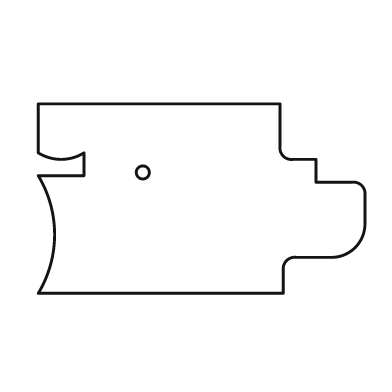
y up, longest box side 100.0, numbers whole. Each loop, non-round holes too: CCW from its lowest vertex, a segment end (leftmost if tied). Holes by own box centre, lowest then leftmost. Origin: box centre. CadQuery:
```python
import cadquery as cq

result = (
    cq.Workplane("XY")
    .moveTo(-50.0, -29.0)
    .lineTo(25.0, -29.0)
    .lineTo(25.0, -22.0)
    .threePointArc((26.0, -19.0), (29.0, -18.0))
    .lineTo(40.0, -18.0)
    .threePointArc((47.0, -15.0), (50.0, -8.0))
    .lineTo(50.0, 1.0)
    .threePointArc((49.0, 4.0), (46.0, 5.0))
    .lineTo(35.0, 5.0)
    .lineTo(35.0, 12.0)
    .lineTo(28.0, 12.0)
    .threePointArc((25.0, 13.0), (24.0, 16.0))
    .lineTo(24.0, 29.0)
    .lineTo(-50.0, 29.0)
    .lineTo(-50.0, 14.0)
    .threePointArc((-43.0, 12.0), (-36.0, 14.0))
    .lineTo(-36.0, 7.0)
    .lineTo(-50.0, 7.0)
    .threePointArc((-45.0, -11.0), (-50.0, -29.0))
    .close()
    .moveTo(-18.0, 8.0)
    .circle(2.0)
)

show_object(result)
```